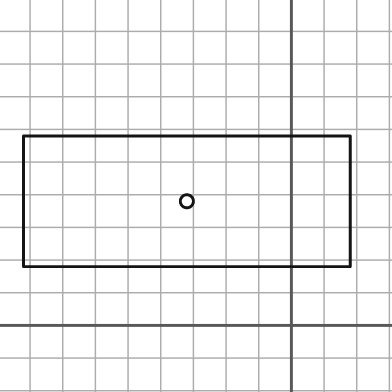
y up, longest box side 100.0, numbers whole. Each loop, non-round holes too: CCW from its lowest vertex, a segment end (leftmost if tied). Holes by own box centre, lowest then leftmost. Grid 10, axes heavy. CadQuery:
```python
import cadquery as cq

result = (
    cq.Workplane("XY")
    .moveTo(-82.0, 18.0)
    .lineTo(18.0, 18.0)
    .lineTo(18.0, 58.0)
    .lineTo(-82.0, 58.0)
    .close()
    .moveTo(-32.0, 38.0)
    .circle(2.0)
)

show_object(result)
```